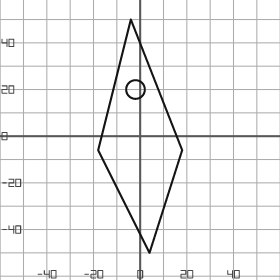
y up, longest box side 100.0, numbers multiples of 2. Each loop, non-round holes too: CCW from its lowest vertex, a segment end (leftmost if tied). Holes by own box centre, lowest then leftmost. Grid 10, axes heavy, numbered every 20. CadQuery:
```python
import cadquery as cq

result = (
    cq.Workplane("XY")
    .moveTo(4.0, -50.0)
    .lineTo(18.0, -6.0)
    .lineTo(-4.0, 50.0)
    .lineTo(-18.0, -6.0)
    .close()
    .moveTo(-2.0, 20.0)
    .circle(4.0)
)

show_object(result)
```